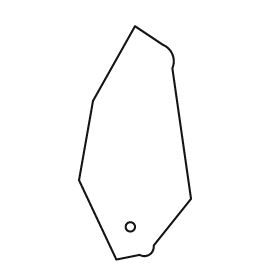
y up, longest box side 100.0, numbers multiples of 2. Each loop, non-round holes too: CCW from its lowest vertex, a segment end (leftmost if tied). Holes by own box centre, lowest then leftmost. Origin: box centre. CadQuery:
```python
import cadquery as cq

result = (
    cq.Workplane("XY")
    .moveTo(-8.0, -50.0)
    .lineTo(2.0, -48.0)
    .threePointArc((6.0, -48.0), (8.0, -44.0))
    .lineTo(24.0, -24.0)
    .lineTo(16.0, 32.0)
    .threePointArc((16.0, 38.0), (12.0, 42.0))
    .lineTo(0.0, 50.0)
    .lineTo(-18.0, 18.0)
    .lineTo(-24.0, -16.0)
    .close()
    .moveTo(-2.0, -36.0)
    .circle(2.0)
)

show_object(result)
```